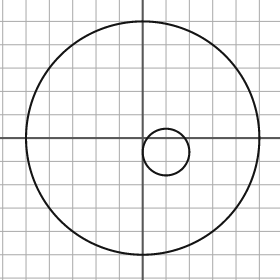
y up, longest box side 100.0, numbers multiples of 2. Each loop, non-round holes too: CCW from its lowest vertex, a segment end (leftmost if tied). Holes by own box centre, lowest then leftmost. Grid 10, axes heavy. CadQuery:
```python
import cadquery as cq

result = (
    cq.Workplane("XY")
    .moveTo(0.0, 0.0)
    .circle(50.0)
    .moveTo(10.0, -6.0)
    .circle(10.0)
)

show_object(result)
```